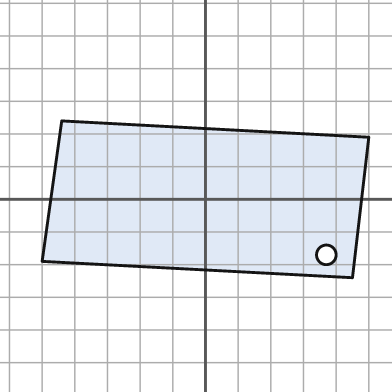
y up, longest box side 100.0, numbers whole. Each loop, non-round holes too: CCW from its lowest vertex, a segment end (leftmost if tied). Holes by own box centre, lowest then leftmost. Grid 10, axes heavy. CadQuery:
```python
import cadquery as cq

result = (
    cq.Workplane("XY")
    .moveTo(45.0, -24.0)
    .lineTo(50.0, 19.0)
    .lineTo(-44.0, 24.0)
    .lineTo(-50.0, -19.0)
    .close()
    .moveTo(37.0, -17.0)
    .circle(3.0)
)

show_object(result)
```